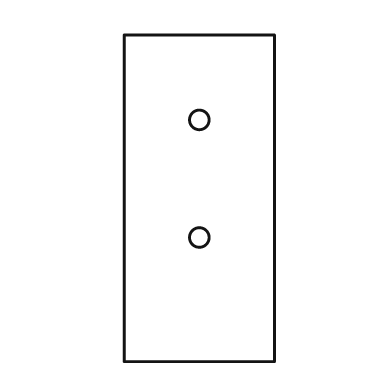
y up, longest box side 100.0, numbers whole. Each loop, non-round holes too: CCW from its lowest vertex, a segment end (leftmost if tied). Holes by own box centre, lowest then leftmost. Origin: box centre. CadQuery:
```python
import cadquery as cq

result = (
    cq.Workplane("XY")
    .moveTo(-23.0, -50.0)
    .lineTo(23.0, -50.0)
    .lineTo(23.0, 50.0)
    .lineTo(-23.0, 50.0)
    .close()
    .moveTo(0.0, -12.0)
    .circle(3.0)
    .moveTo(0.0, 24.0)
    .circle(3.0)
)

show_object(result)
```